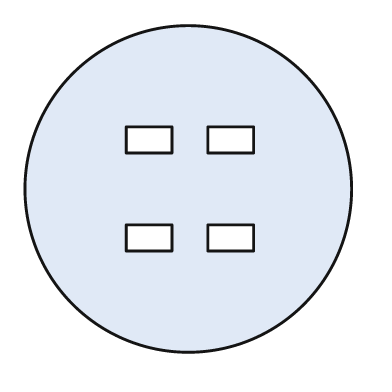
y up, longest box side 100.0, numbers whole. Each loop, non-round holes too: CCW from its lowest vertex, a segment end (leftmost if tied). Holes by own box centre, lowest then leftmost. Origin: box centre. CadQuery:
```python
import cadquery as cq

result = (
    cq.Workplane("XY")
    .moveTo(0.0, 0.0)
    .circle(50.0)
    .moveTo(-19.0, -19.0)
    .lineTo(-5.0, -19.0)
    .lineTo(-5.0, -11.0)
    .lineTo(-19.0, -11.0)
    .close()
    .moveTo(6.0, -19.0)
    .lineTo(20.0, -19.0)
    .lineTo(20.0, -11.0)
    .lineTo(6.0, -11.0)
    .close()
    .moveTo(-19.0, 11.0)
    .lineTo(-5.0, 11.0)
    .lineTo(-5.0, 19.0)
    .lineTo(-19.0, 19.0)
    .close()
    .moveTo(6.0, 11.0)
    .lineTo(20.0, 11.0)
    .lineTo(20.0, 19.0)
    .lineTo(6.0, 19.0)
    .close()
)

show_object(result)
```